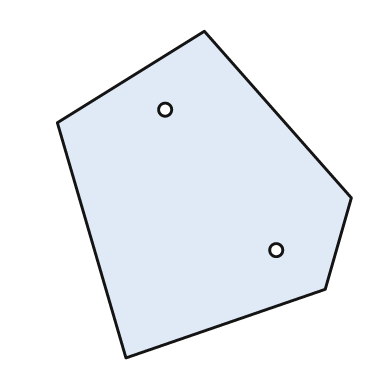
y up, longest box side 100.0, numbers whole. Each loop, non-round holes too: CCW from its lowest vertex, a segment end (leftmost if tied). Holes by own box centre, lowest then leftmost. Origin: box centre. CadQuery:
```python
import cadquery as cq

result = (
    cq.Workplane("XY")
    .moveTo(-24.0, -50.0)
    .lineTo(37.0, -29.0)
    .lineTo(45.0, -1.0)
    .lineTo(0.0, 50.0)
    .lineTo(-45.0, 22.0)
    .close()
    .moveTo(22.0, -17.0)
    .circle(2.0)
    .moveTo(-12.0, 26.0)
    .circle(2.0)
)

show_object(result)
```